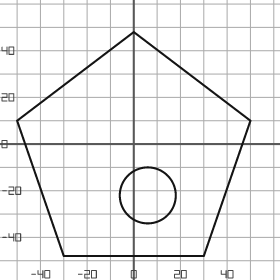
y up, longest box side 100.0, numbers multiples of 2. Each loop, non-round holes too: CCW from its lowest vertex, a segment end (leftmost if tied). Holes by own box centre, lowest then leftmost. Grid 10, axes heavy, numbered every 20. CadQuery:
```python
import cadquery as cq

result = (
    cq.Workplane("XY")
    .moveTo(-30.0, -48.0)
    .lineTo(30.0, -48.0)
    .lineTo(50.0, 10.0)
    .lineTo(0.0, 48.0)
    .lineTo(-50.0, 10.0)
    .close()
    .moveTo(6.0, -22.0)
    .circle(12.0)
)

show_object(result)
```